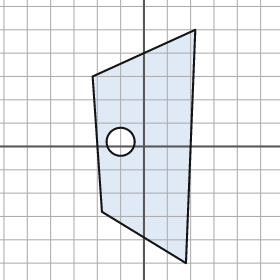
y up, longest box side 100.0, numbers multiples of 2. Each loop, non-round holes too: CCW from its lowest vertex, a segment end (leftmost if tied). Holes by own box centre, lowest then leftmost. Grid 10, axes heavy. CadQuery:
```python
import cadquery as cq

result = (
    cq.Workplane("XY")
    .moveTo(18.0, -50.0)
    .lineTo(22.0, 50.0)
    .lineTo(-22.0, 30.0)
    .lineTo(-18.0, -28.0)
    .close()
    .moveTo(-10.0, 2.0)
    .circle(6.0)
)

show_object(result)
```